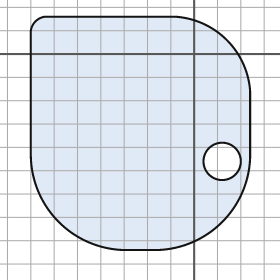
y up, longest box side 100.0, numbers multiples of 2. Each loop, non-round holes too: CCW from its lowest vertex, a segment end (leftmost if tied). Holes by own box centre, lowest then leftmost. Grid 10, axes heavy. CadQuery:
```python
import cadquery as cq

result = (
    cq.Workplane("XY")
    .moveTo(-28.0, -84.0)
    .lineTo(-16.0, -84.0)
    .threePointArc((12.0, -72.0), (24.0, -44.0))
    .lineTo(24.0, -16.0)
    .threePointArc((14.0, 6.0), (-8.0, 16.0))
    .lineTo(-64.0, 16.0)
    .threePointArc((-68.0, 14.0), (-70.0, 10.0))
    .lineTo(-70.0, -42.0)
    .threePointArc((-58.0, -72.0), (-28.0, -84.0))
    .close()
    .moveTo(12.0, -46.0)
    .circle(8.0)
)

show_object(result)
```